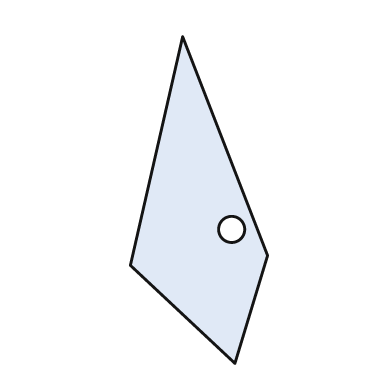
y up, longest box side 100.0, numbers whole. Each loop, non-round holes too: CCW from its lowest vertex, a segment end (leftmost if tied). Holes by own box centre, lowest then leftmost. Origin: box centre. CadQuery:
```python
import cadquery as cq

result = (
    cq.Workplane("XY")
    .moveTo(11.0, -50.0)
    .lineTo(21.0, -17.0)
    .lineTo(-5.0, 50.0)
    .lineTo(-21.0, -20.0)
    .close()
    .moveTo(10.0, -9.0)
    .circle(4.0)
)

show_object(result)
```